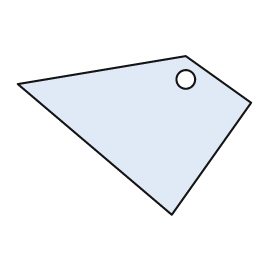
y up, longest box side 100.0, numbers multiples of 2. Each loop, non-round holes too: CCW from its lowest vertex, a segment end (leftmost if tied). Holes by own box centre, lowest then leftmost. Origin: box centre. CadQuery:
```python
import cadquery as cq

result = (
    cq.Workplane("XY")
    .moveTo(16.0, -34.0)
    .lineTo(50.0, 14.0)
    .lineTo(22.0, 34.0)
    .lineTo(-50.0, 22.0)
    .close()
    .moveTo(22.0, 24.0)
    .circle(4.0)
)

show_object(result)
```